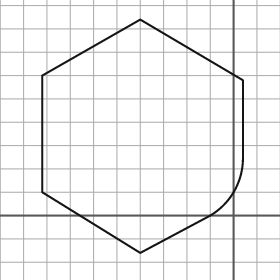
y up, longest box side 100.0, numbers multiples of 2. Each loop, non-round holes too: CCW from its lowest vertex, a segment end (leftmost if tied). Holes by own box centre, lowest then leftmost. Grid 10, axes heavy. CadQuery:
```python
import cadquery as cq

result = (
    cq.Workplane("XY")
    .moveTo(-40.0, -16.0)
    .lineTo(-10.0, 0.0)
    .threePointArc((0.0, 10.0), (4.0, 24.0))
    .lineTo(4.0, 58.0)
    .lineTo(-40.0, 84.0)
    .lineTo(-82.0, 60.0)
    .lineTo(-82.0, 10.0)
    .close()
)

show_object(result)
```